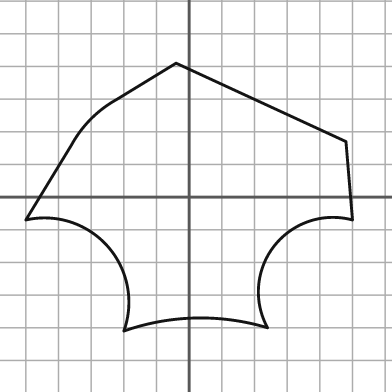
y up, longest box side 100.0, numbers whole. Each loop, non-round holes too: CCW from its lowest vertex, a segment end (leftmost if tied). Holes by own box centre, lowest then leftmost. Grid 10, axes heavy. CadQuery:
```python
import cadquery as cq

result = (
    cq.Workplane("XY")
    .moveTo(-20.0, -41.0)
    .threePointArc((2.0, -37.0), (24.0, -40.0))
    .threePointArc((26.0, -15.0), (50.0, -7.0))
    .lineTo(48.0, 17.0)
    .lineTo(-4.0, 41.0)
    .lineTo(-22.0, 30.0)
    .threePointArc((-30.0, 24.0), (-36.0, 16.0))
    .lineTo(-50.0, -7.0)
    .threePointArc((-25.0, -15.0), (-20.0, -41.0))
    .close()
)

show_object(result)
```